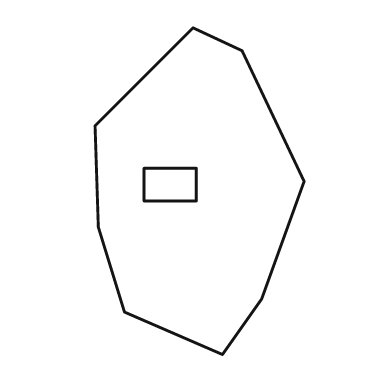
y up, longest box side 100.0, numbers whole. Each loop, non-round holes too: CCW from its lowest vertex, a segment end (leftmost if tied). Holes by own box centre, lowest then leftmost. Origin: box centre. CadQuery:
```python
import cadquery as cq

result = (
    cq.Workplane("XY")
    .moveTo(7.0, -50.0)
    .lineTo(19.0, -33.0)
    .lineTo(32.0, 3.0)
    .lineTo(13.0, 43.0)
    .lineTo(-2.0, 50.0)
    .lineTo(-32.0, 20.0)
    .lineTo(-31.0, -11.0)
    .lineTo(-23.0, -37.0)
    .close()
    .moveTo(-17.0, -3.0)
    .lineTo(-1.0, -3.0)
    .lineTo(-1.0, 7.0)
    .lineTo(-17.0, 7.0)
    .close()
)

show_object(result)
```